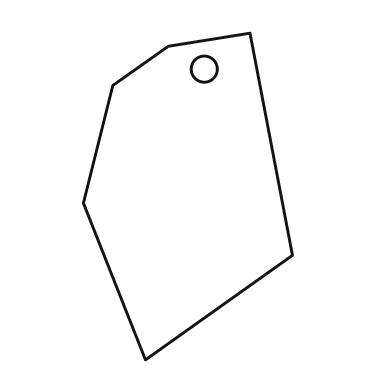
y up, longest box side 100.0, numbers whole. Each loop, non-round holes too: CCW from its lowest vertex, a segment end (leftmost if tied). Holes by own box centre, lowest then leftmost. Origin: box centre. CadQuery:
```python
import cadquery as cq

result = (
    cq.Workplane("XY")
    .moveTo(-13.0, -50.0)
    .lineTo(32.0, -18.0)
    .lineTo(19.0, 50.0)
    .lineTo(-6.0, 46.0)
    .lineTo(-23.0, 34.0)
    .lineTo(-32.0, -2.0)
    .close()
    .moveTo(5.0, 39.0)
    .circle(4.0)
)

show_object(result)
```